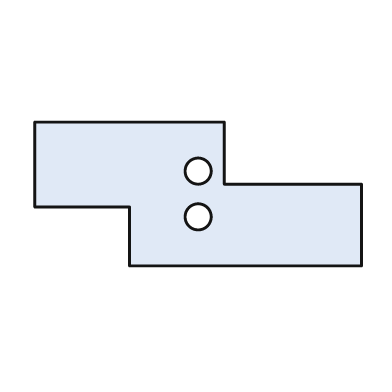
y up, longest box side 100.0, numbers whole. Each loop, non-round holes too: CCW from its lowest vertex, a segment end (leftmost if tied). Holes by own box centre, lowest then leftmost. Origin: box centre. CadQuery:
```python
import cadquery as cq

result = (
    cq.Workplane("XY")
    .moveTo(-21.0, -22.0)
    .lineTo(50.0, -22.0)
    .lineTo(50.0, 3.0)
    .lineTo(8.0, 3.0)
    .lineTo(8.0, 22.0)
    .lineTo(-50.0, 22.0)
    .lineTo(-50.0, -4.0)
    .lineTo(-21.0, -4.0)
    .close()
    .moveTo(0.0, -7.0)
    .circle(4.0)
    .moveTo(0.0, 7.0)
    .circle(4.0)
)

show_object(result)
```